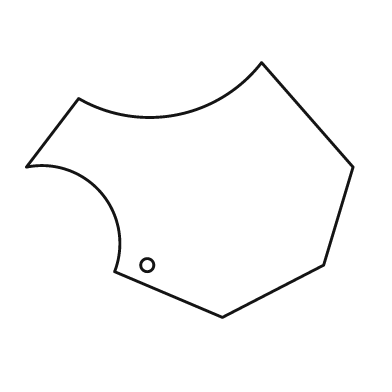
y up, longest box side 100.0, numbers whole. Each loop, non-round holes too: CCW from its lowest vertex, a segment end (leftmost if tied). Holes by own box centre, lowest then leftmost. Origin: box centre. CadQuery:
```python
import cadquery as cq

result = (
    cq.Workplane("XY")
    .moveTo(10.0, -39.0)
    .lineTo(41.0, -23.0)
    .lineTo(50.0, 7.0)
    .lineTo(22.0, 39.0)
    .threePointArc((-4.0, 23.0), (-34.0, 28.0))
    .lineTo(-50.0, 7.0)
    .threePointArc((-27.0, -1.0), (-23.0, -25.0))
    .close()
    .moveTo(-13.0, -23.0)
    .circle(2.0)
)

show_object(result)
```